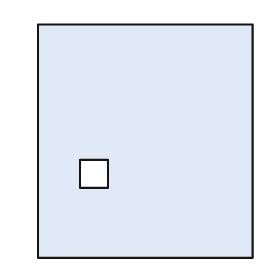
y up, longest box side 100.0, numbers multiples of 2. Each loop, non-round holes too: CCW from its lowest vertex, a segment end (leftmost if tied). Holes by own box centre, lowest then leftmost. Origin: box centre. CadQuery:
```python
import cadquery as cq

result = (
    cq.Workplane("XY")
    .moveTo(-46.0, -50.0)
    .lineTo(46.0, -50.0)
    .lineTo(46.0, 50.0)
    .lineTo(-46.0, 50.0)
    .close()
    .moveTo(-28.0, -20.0)
    .lineTo(-16.0, -20.0)
    .lineTo(-16.0, -8.0)
    .lineTo(-28.0, -8.0)
    .close()
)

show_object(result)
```